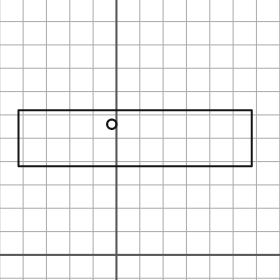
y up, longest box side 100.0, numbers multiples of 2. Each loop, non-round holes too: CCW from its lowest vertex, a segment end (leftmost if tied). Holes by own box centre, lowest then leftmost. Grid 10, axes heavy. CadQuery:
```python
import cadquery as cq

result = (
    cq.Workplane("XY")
    .moveTo(-42.0, 38.0)
    .lineTo(58.0, 38.0)
    .lineTo(58.0, 62.0)
    .lineTo(-42.0, 62.0)
    .close()
    .moveTo(-2.0, 56.0)
    .circle(2.0)
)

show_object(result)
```